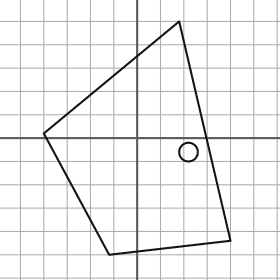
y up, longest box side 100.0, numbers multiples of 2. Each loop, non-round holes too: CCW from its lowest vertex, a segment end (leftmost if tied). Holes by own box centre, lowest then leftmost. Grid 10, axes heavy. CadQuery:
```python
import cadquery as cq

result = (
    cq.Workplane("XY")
    .moveTo(-12.0, -50.0)
    .lineTo(40.0, -44.0)
    .lineTo(18.0, 50.0)
    .lineTo(-40.0, 2.0)
    .close()
    .moveTo(22.0, -6.0)
    .circle(4.0)
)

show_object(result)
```